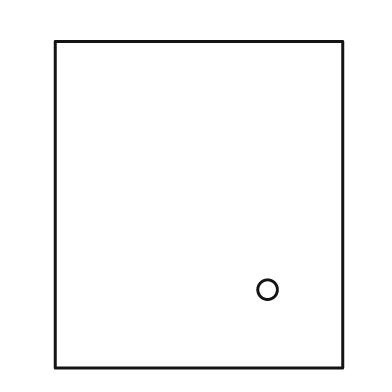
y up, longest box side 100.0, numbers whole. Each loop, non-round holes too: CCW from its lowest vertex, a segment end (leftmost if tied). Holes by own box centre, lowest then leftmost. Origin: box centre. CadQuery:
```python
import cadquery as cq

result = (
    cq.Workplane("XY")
    .moveTo(-44.0, -50.0)
    .lineTo(44.0, -50.0)
    .lineTo(44.0, 50.0)
    .lineTo(-44.0, 50.0)
    .close()
    .moveTo(21.0, -26.0)
    .circle(3.0)
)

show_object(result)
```